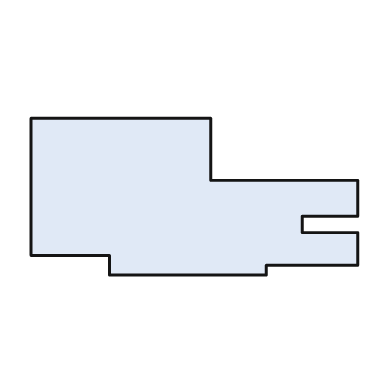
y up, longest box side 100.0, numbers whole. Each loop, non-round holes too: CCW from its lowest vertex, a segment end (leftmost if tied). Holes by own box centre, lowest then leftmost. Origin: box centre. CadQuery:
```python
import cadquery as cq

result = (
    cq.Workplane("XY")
    .moveTo(-26.0, -24.0)
    .lineTo(22.0, -24.0)
    .lineTo(22.0, -21.0)
    .lineTo(50.0, -21.0)
    .lineTo(50.0, -11.0)
    .lineTo(33.0, -11.0)
    .lineTo(33.0, -6.0)
    .lineTo(50.0, -6.0)
    .lineTo(50.0, 5.0)
    .lineTo(5.0, 5.0)
    .lineTo(5.0, 24.0)
    .lineTo(-50.0, 24.0)
    .lineTo(-50.0, -18.0)
    .lineTo(-26.0, -18.0)
    .close()
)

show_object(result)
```